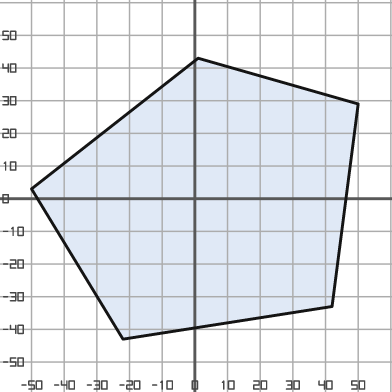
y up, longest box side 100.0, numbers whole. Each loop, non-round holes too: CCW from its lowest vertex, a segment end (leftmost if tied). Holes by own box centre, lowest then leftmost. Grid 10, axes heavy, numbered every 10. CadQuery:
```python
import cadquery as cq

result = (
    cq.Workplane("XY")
    .moveTo(-22.0, -43.0)
    .lineTo(42.0, -33.0)
    .lineTo(50.0, 29.0)
    .lineTo(1.0, 43.0)
    .lineTo(-50.0, 3.0)
    .close()
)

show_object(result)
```